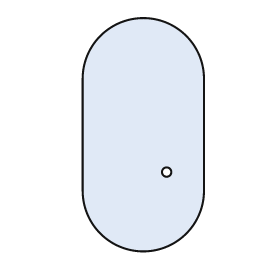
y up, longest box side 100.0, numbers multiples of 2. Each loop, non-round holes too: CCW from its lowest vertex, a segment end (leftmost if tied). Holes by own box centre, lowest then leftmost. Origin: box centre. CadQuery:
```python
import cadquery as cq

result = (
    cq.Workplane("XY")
    .moveTo(-26.0, -24.0)
    .threePointArc((0.0, -50.0), (26.0, -24.0))
    .lineTo(26.0, 24.0)
    .threePointArc((0.0, 50.0), (-26.0, 24.0))
    .close()
    .moveTo(10.0, -16.0)
    .circle(2.0)
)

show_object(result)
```